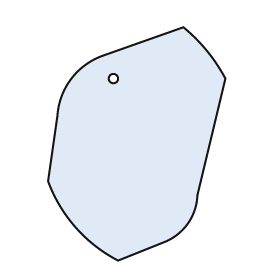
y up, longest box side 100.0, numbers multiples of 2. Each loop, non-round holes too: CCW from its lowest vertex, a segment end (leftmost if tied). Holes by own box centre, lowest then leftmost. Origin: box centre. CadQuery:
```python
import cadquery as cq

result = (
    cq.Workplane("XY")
    .moveTo(-8.0, -50.0)
    .lineTo(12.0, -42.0)
    .threePointArc((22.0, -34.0), (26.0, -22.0))
    .lineTo(38.0, 28.0)
    .threePointArc((30.0, 40.0), (20.0, 50.0))
    .lineTo(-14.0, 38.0)
    .threePointArc((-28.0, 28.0), (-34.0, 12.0))
    .lineTo(-38.0, -16.0)
    .threePointArc((-26.0, -36.0), (-8.0, -50.0))
    .close()
    .moveTo(-10.0, 28.0)
    .circle(2.0)
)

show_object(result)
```